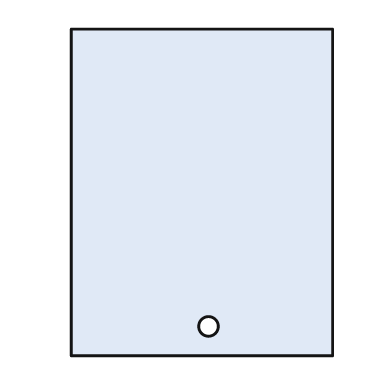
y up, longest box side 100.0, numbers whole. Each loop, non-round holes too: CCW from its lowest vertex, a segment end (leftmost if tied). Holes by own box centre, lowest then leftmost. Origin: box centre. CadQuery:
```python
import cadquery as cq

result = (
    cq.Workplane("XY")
    .moveTo(-40.0, -50.0)
    .lineTo(40.0, -50.0)
    .lineTo(40.0, 50.0)
    .lineTo(-40.0, 50.0)
    .close()
    .moveTo(2.0, -41.0)
    .circle(3.0)
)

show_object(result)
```